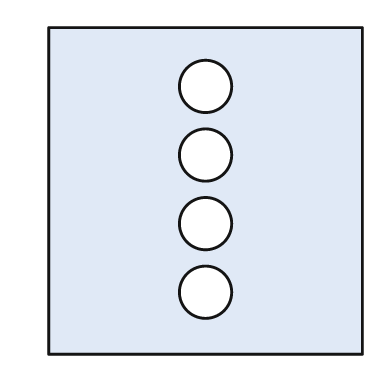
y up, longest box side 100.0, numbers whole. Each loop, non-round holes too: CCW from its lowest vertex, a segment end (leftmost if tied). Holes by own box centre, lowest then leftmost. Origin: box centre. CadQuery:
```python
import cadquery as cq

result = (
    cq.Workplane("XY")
    .moveTo(-48.0, -50.0)
    .lineTo(48.0, -50.0)
    .lineTo(48.0, 50.0)
    .lineTo(-48.0, 50.0)
    .close()
    .moveTo(0.0, -31.0)
    .circle(8.0)
    .moveTo(0.0, -10.0)
    .circle(8.0)
    .moveTo(0.0, 11.0)
    .circle(8.0)
    .moveTo(0.0, 32.0)
    .circle(8.0)
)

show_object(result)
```